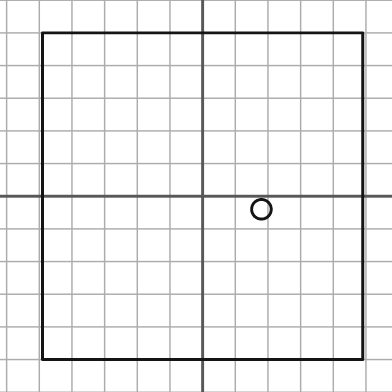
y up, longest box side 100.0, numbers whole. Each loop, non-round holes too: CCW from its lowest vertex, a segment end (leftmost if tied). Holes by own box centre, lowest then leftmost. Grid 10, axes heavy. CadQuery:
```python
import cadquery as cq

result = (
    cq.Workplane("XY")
    .moveTo(-49.0, -50.0)
    .lineTo(49.0, -50.0)
    .lineTo(49.0, 50.0)
    .lineTo(-49.0, 50.0)
    .close()
    .moveTo(18.0, -4.0)
    .circle(3.0)
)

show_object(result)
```